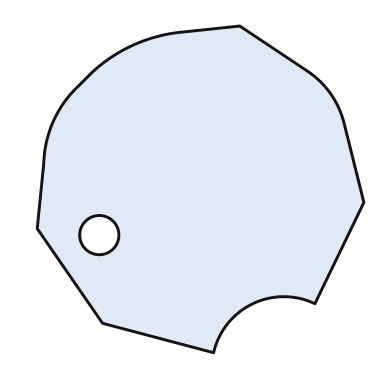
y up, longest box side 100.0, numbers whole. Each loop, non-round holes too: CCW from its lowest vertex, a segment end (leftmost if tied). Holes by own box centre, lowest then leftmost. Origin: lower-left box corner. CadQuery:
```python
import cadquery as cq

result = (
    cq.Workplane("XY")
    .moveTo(54.0, 0.0)
    .threePointArc((66.0, 15.0), (85.0, 15.0))
    .lineTo(100.0, 46.0)
    .lineTo(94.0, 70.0)
    .threePointArc((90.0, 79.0), (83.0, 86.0))
    .lineTo(62.0, 100.0)
    .lineTo(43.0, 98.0)
    .threePointArc((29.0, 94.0), (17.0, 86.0))
    .lineTo(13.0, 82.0)
    .threePointArc((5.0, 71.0), (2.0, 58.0))
    .lineTo(0.0, 38.0)
    .lineTo(20.0, 9.0)
    .close()
    .moveTo(19.0, 36.0)
    .circle(6.0)
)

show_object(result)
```